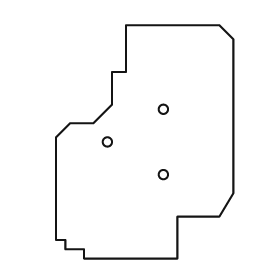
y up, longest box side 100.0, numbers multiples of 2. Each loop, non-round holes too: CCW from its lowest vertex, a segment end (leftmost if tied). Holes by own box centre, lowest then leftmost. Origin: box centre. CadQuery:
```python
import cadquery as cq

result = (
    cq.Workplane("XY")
    .moveTo(-26.0, -50.0)
    .lineTo(14.0, -50.0)
    .lineTo(14.0, -32.0)
    .lineTo(32.0, -32.0)
    .lineTo(38.0, -22.0)
    .lineTo(38.0, 44.0)
    .lineTo(32.0, 50.0)
    .lineTo(-8.0, 50.0)
    .lineTo(-8.0, 30.0)
    .lineTo(-14.0, 30.0)
    .lineTo(-14.0, 16.0)
    .lineTo(-22.0, 8.0)
    .lineTo(-32.0, 8.0)
    .lineTo(-38.0, 2.0)
    .lineTo(-38.0, -42.0)
    .lineTo(-34.0, -42.0)
    .lineTo(-34.0, -46.0)
    .lineTo(-26.0, -46.0)
    .close()
    .moveTo(8.0, -14.0)
    .circle(2.0)
    .moveTo(-16.0, 0.0)
    .circle(2.0)
    .moveTo(8.0, 14.0)
    .circle(2.0)
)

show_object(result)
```